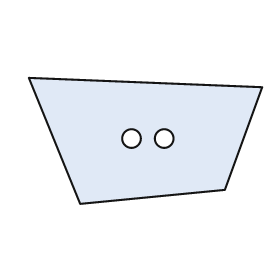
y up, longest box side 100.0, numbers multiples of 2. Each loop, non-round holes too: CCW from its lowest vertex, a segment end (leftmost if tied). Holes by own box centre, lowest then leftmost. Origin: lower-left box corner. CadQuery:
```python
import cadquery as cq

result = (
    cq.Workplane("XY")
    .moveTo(22.0, 0.0)
    .lineTo(84.0, 6.0)
    .lineTo(100.0, 50.0)
    .lineTo(0.0, 54.0)
    .close()
    .moveTo(44.0, 28.0)
    .circle(4.0)
    .moveTo(58.0, 28.0)
    .circle(4.0)
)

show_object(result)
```